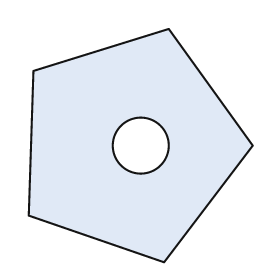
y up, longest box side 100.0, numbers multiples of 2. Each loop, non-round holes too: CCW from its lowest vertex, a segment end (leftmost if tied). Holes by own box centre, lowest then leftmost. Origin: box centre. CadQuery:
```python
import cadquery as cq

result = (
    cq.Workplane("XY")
    .moveTo(10.0, -50.0)
    .lineTo(48.0, 0.0)
    .lineTo(12.0, 50.0)
    .lineTo(-46.0, 32.0)
    .lineTo(-48.0, -30.0)
    .close()
    .moveTo(0.0, 0.0)
    .circle(12.0)
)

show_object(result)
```